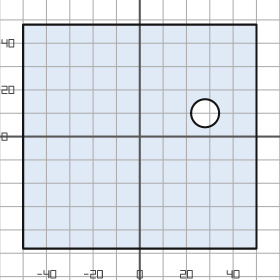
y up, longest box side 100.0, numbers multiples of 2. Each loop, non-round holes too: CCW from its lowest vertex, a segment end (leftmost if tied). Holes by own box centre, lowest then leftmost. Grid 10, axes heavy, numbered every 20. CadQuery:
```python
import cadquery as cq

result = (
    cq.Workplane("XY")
    .moveTo(-50.0, -48.0)
    .lineTo(50.0, -48.0)
    .lineTo(50.0, 48.0)
    .lineTo(-50.0, 48.0)
    .close()
    .moveTo(28.0, 10.0)
    .circle(6.0)
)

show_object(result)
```